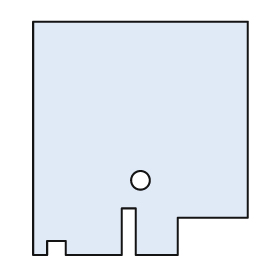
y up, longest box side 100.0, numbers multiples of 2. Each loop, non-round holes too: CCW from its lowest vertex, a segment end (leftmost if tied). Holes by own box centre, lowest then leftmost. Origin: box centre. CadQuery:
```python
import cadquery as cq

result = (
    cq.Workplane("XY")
    .moveTo(-46.0, -50.0)
    .lineTo(-40.0, -50.0)
    .lineTo(-40.0, -44.0)
    .lineTo(-32.0, -44.0)
    .lineTo(-32.0, -50.0)
    .lineTo(-8.0, -50.0)
    .lineTo(-8.0, -30.0)
    .lineTo(-2.0, -30.0)
    .lineTo(-2.0, -50.0)
    .lineTo(16.0, -50.0)
    .lineTo(16.0, -34.0)
    .lineTo(46.0, -34.0)
    .lineTo(46.0, 50.0)
    .lineTo(-46.0, 50.0)
    .close()
    .moveTo(0.0, -18.0)
    .circle(4.0)
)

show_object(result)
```